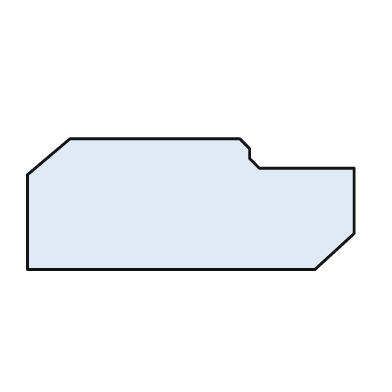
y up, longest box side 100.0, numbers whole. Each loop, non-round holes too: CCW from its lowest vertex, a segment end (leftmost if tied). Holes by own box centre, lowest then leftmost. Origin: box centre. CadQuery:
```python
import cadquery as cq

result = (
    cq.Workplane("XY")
    .moveTo(-50.0, -20.0)
    .lineTo(38.0, -20.0)
    .lineTo(50.0, -9.0)
    .lineTo(50.0, 11.0)
    .lineTo(21.0, 11.0)
    .lineTo(18.0, 14.0)
    .lineTo(18.0, 17.0)
    .lineTo(15.0, 20.0)
    .lineTo(-37.0, 20.0)
    .lineTo(-50.0, 9.0)
    .close()
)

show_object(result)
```